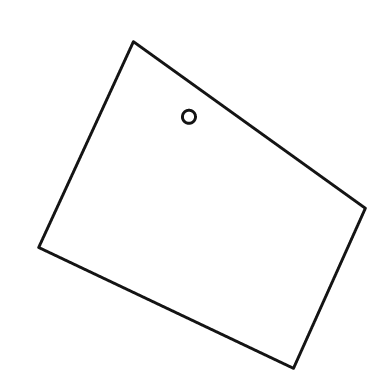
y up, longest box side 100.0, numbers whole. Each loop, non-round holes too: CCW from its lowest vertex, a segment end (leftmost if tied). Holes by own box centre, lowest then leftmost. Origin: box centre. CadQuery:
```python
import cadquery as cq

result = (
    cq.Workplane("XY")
    .moveTo(28.0, -50.0)
    .lineTo(50.0, -1.0)
    .lineTo(-21.0, 50.0)
    .lineTo(-50.0, -13.0)
    .close()
    .moveTo(-4.0, 27.0)
    .circle(2.0)
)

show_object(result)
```